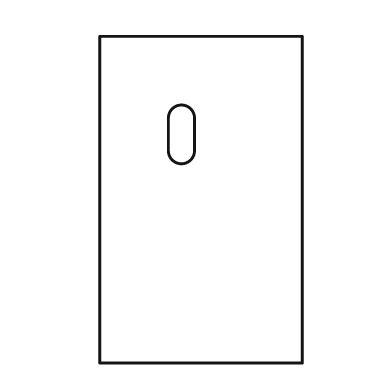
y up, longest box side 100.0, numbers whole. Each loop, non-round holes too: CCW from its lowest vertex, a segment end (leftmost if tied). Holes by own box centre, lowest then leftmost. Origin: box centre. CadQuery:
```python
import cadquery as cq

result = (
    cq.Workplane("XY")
    .moveTo(-31.0, -50.0)
    .lineTo(31.0, -50.0)
    .lineTo(31.0, 50.0)
    .lineTo(-31.0, 50.0)
    .close()
    .moveTo(-10.0, 15.0)
    .threePointArc((-6.0, 11.0), (-2.0, 15.0))
    .lineTo(-2.0, 25.0)
    .threePointArc((-6.0, 29.0), (-10.0, 25.0))
    .close()
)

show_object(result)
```